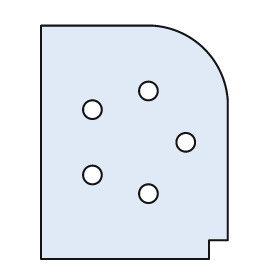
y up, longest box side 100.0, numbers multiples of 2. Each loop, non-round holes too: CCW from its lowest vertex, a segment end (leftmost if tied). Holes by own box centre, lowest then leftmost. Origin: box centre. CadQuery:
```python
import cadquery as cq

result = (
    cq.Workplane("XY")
    .moveTo(-40.0, -50.0)
    .lineTo(32.0, -50.0)
    .lineTo(32.0, -42.0)
    .lineTo(40.0, -42.0)
    .lineTo(40.0, 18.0)
    .threePointArc((30.0, 40.0), (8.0, 50.0))
    .lineTo(-40.0, 50.0)
    .close()
    .moveTo(6.0, -22.0)
    .circle(4.0)
    .moveTo(-18.0, -14.0)
    .circle(4.0)
    .moveTo(22.0, 0.0)
    .circle(4.0)
    .moveTo(-18.0, 14.0)
    .circle(4.0)
    .moveTo(6.0, 22.0)
    .circle(4.0)
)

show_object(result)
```